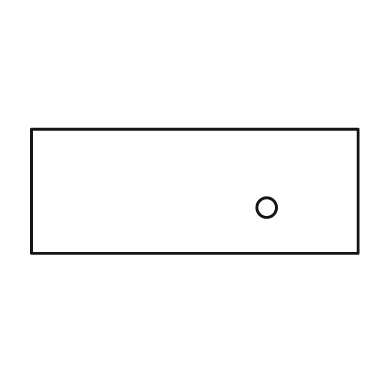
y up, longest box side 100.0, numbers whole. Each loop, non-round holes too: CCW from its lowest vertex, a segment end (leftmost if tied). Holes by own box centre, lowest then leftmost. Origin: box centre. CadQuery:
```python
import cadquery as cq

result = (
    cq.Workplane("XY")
    .moveTo(-50.0, -19.0)
    .lineTo(50.0, -19.0)
    .lineTo(50.0, 19.0)
    .lineTo(-50.0, 19.0)
    .close()
    .moveTo(22.0, -5.0)
    .circle(3.0)
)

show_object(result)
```